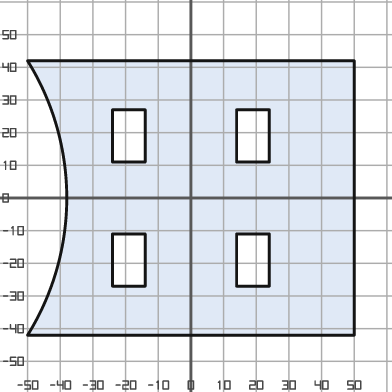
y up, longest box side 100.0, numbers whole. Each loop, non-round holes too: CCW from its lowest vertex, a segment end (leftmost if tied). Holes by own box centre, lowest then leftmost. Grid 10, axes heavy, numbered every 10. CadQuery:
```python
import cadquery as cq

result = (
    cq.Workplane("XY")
    .moveTo(-50.0, -42.0)
    .lineTo(50.0, -42.0)
    .lineTo(50.0, 42.0)
    .lineTo(-50.0, 42.0)
    .threePointArc((-38.0, 0.0), (-50.0, -42.0))
    .close()
    .moveTo(-24.0, -27.0)
    .lineTo(-14.0, -27.0)
    .lineTo(-14.0, -11.0)
    .lineTo(-24.0, -11.0)
    .close()
    .moveTo(14.0, -27.0)
    .lineTo(24.0, -27.0)
    .lineTo(24.0, -11.0)
    .lineTo(14.0, -11.0)
    .close()
    .moveTo(-24.0, 11.0)
    .lineTo(-14.0, 11.0)
    .lineTo(-14.0, 27.0)
    .lineTo(-24.0, 27.0)
    .close()
    .moveTo(14.0, 11.0)
    .lineTo(24.0, 11.0)
    .lineTo(24.0, 27.0)
    .lineTo(14.0, 27.0)
    .close()
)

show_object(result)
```